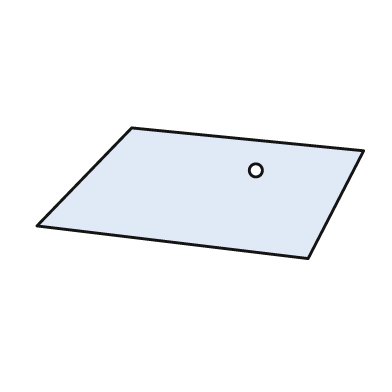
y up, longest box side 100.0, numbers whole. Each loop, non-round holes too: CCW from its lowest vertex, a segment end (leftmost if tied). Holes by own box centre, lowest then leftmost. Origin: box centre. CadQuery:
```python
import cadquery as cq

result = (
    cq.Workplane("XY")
    .moveTo(33.0, -20.0)
    .lineTo(50.0, 13.0)
    .lineTo(-21.0, 20.0)
    .lineTo(-50.0, -10.0)
    .close()
    .moveTo(17.0, 7.0)
    .circle(2.0)
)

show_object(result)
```